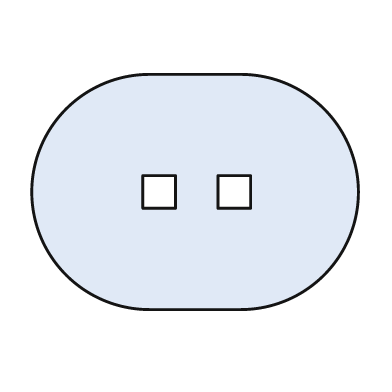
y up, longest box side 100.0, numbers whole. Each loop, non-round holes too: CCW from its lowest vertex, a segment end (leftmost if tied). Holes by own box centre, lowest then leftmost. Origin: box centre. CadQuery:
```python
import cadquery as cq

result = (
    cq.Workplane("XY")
    .moveTo(-14.0, -36.0)
    .lineTo(14.0, -36.0)
    .threePointArc((50.0, 0.0), (14.0, 36.0))
    .lineTo(-14.0, 36.0)
    .threePointArc((-50.0, 0.0), (-14.0, -36.0))
    .close()
    .moveTo(-16.0, -5.0)
    .lineTo(-6.0, -5.0)
    .lineTo(-6.0, 5.0)
    .lineTo(-16.0, 5.0)
    .close()
    .moveTo(7.0, -5.0)
    .lineTo(17.0, -5.0)
    .lineTo(17.0, 5.0)
    .lineTo(7.0, 5.0)
    .close()
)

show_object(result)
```